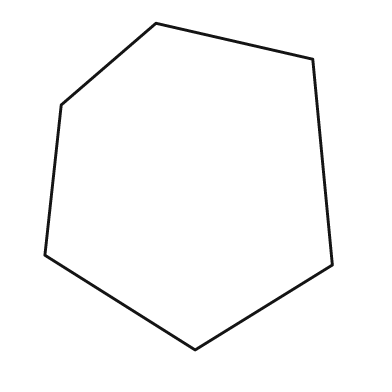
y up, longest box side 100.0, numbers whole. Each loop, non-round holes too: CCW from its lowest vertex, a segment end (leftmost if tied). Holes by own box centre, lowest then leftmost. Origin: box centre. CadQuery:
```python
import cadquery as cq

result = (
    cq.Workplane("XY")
    .moveTo(2.0, -50.0)
    .lineTo(44.0, -24.0)
    .lineTo(38.0, 39.0)
    .lineTo(-10.0, 50.0)
    .lineTo(-39.0, 25.0)
    .lineTo(-44.0, -21.0)
    .close()
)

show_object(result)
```